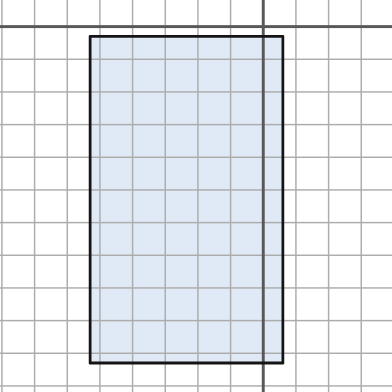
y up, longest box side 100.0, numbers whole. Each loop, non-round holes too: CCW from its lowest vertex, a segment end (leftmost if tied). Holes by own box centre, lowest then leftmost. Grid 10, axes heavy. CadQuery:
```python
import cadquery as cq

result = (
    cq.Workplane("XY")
    .moveTo(-53.0, -103.0)
    .lineTo(6.0, -103.0)
    .lineTo(6.0, -3.0)
    .lineTo(-53.0, -3.0)
    .close()
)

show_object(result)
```